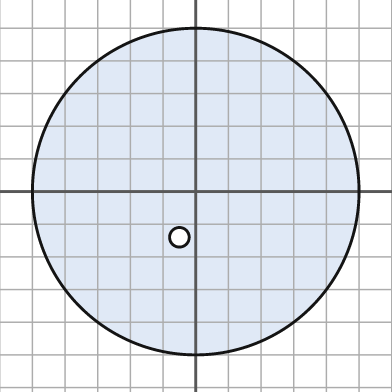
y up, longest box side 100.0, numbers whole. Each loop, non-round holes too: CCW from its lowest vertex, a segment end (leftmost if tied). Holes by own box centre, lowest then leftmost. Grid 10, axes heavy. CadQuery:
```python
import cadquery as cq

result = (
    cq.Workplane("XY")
    .moveTo(0.0, 0.0)
    .circle(50.0)
    .moveTo(-5.0, -14.0)
    .circle(3.0)
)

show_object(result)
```